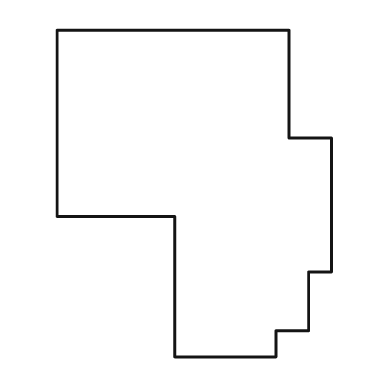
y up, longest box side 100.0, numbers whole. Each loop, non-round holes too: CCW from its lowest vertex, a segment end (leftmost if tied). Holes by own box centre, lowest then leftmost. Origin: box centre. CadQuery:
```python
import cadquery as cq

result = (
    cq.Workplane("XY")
    .moveTo(-6.0, -50.0)
    .lineTo(25.0, -50.0)
    .lineTo(25.0, -42.0)
    .lineTo(35.0, -42.0)
    .lineTo(35.0, -24.0)
    .lineTo(42.0, -24.0)
    .lineTo(42.0, 17.0)
    .lineTo(29.0, 17.0)
    .lineTo(29.0, 50.0)
    .lineTo(-42.0, 50.0)
    .lineTo(-42.0, -7.0)
    .lineTo(-6.0, -7.0)
    .close()
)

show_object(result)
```